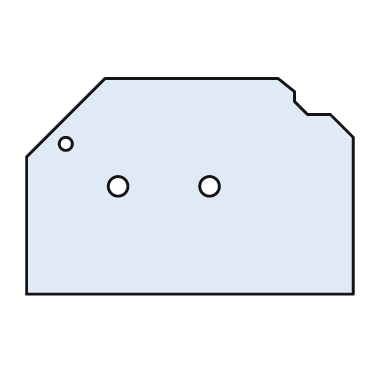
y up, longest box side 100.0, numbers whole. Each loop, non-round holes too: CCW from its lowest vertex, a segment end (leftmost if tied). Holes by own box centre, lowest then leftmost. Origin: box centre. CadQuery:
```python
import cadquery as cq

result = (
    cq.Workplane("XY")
    .moveTo(-50.0, -33.0)
    .lineTo(50.0, -33.0)
    .lineTo(50.0, 15.0)
    .lineTo(43.0, 22.0)
    .lineTo(36.0, 22.0)
    .lineTo(32.0, 26.0)
    .lineTo(32.0, 29.0)
    .lineTo(27.0, 33.0)
    .lineTo(-26.0, 33.0)
    .lineTo(-50.0, 9.0)
    .close()
    .moveTo(-22.0, 0.0)
    .circle(3.0)
    .moveTo(6.0, 0.0)
    .circle(3.0)
    .moveTo(-38.0, 13.0)
    .circle(2.0)
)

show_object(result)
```